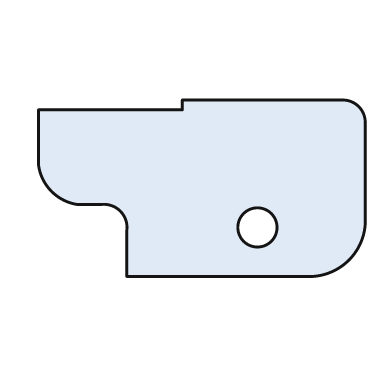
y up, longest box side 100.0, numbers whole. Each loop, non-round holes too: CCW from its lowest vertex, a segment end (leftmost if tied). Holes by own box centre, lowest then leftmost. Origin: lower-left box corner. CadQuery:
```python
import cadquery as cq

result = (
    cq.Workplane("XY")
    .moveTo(27.0, 0.0)
    .lineTo(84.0, 0.0)
    .threePointArc((95.0, 5.0), (100.0, 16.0))
    .lineTo(100.0, 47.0)
    .threePointArc((98.0, 52.0), (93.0, 54.0))
    .lineTo(44.0, 54.0)
    .lineTo(44.0, 51.0)
    .lineTo(0.0, 51.0)
    .lineTo(0.0, 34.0)
    .threePointArc((4.0, 26.0), (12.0, 22.0))
    .lineTo(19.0, 22.0)
    .threePointArc((25.0, 20.0), (27.0, 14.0))
    .close()
    .moveTo(67.0, 15.0)
    .circle(6.0)
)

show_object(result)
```